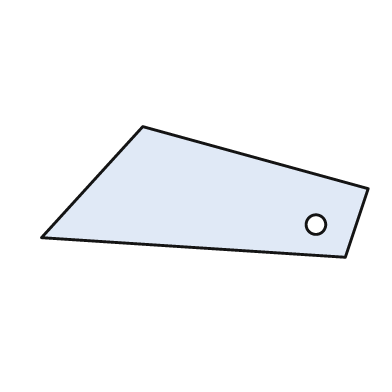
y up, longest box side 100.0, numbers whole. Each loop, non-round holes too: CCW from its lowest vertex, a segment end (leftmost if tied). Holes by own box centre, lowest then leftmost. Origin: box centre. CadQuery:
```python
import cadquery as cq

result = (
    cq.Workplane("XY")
    .moveTo(43.0, -20.0)
    .lineTo(50.0, 1.0)
    .lineTo(-19.0, 20.0)
    .lineTo(-50.0, -14.0)
    .close()
    .moveTo(34.0, -10.0)
    .circle(3.0)
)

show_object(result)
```